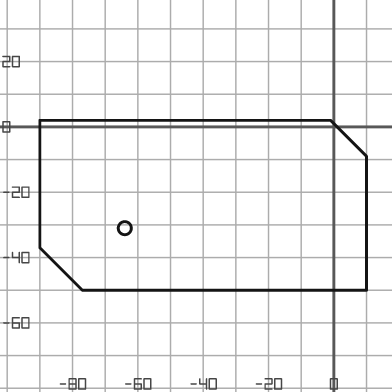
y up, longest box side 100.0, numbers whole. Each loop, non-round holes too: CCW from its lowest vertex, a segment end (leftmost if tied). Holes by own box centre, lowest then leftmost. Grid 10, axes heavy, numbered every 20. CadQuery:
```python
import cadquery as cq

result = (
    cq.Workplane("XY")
    .moveTo(-77.0, -50.0)
    .lineTo(10.0, -50.0)
    .lineTo(10.0, -9.0)
    .lineTo(-1.0, 2.0)
    .lineTo(-90.0, 2.0)
    .lineTo(-90.0, -37.0)
    .close()
    .moveTo(-64.0, -31.0)
    .circle(2.0)
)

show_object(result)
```